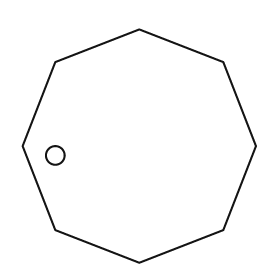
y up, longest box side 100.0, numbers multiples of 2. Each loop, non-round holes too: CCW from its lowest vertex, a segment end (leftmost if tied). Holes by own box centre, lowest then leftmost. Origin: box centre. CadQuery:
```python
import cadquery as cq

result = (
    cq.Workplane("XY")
    .moveTo(0.0, -50.0)
    .lineTo(36.0, -36.0)
    .lineTo(50.0, 0.0)
    .lineTo(36.0, 36.0)
    .lineTo(0.0, 50.0)
    .lineTo(-36.0, 36.0)
    .lineTo(-50.0, 0.0)
    .lineTo(-36.0, -36.0)
    .close()
    .moveTo(-36.0, -4.0)
    .circle(4.0)
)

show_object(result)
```